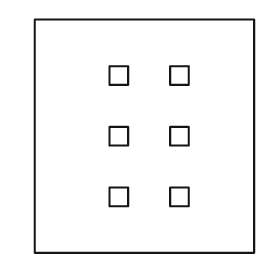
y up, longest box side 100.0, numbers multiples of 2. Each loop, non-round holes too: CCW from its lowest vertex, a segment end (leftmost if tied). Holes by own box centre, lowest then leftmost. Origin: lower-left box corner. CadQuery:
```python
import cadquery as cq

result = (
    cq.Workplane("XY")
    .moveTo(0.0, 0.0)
    .lineTo(94.0, 0.0)
    .lineTo(94.0, 100.0)
    .lineTo(0.0, 100.0)
    .close()
    .moveTo(32.0, 20.0)
    .lineTo(40.0, 20.0)
    .lineTo(40.0, 28.0)
    .lineTo(32.0, 28.0)
    .close()
    .moveTo(58.0, 20.0)
    .lineTo(66.0, 20.0)
    .lineTo(66.0, 28.0)
    .lineTo(58.0, 28.0)
    .close()
    .moveTo(32.0, 46.0)
    .lineTo(40.0, 46.0)
    .lineTo(40.0, 54.0)
    .lineTo(32.0, 54.0)
    .close()
    .moveTo(58.0, 46.0)
    .lineTo(66.0, 46.0)
    .lineTo(66.0, 54.0)
    .lineTo(58.0, 54.0)
    .close()
    .moveTo(32.0, 72.0)
    .lineTo(40.0, 72.0)
    .lineTo(40.0, 80.0)
    .lineTo(32.0, 80.0)
    .close()
    .moveTo(58.0, 72.0)
    .lineTo(66.0, 72.0)
    .lineTo(66.0, 80.0)
    .lineTo(58.0, 80.0)
    .close()
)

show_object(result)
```